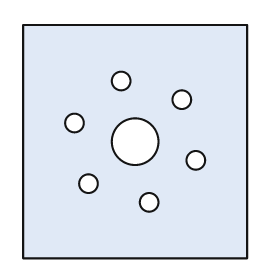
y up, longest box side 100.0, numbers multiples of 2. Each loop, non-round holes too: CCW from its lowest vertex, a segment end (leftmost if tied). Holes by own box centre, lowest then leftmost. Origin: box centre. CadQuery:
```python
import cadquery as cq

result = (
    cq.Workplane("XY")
    .moveTo(-48.0, -50.0)
    .lineTo(48.0, -50.0)
    .lineTo(48.0, 50.0)
    .lineTo(-48.0, 50.0)
    .close()
    .moveTo(6.0, -26.0)
    .circle(4.0)
    .moveTo(-20.0, -18.0)
    .circle(4.0)
    .moveTo(26.0, -8.0)
    .circle(4.0)
    .moveTo(0.0, 0.0)
    .circle(10.0)
    .moveTo(-26.0, 8.0)
    .circle(4.0)
    .moveTo(20.0, 18.0)
    .circle(4.0)
    .moveTo(-6.0, 26.0)
    .circle(4.0)
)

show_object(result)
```